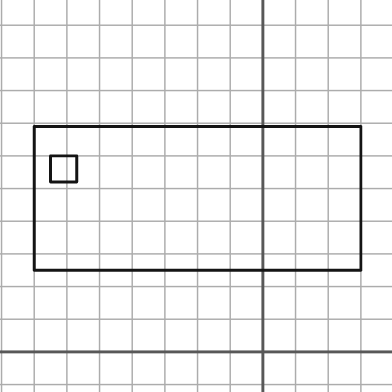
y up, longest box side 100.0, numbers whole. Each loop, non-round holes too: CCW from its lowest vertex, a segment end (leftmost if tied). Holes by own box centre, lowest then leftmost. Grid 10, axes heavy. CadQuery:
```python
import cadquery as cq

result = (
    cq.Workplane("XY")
    .moveTo(-70.0, 25.0)
    .lineTo(30.0, 25.0)
    .lineTo(30.0, 69.0)
    .lineTo(-70.0, 69.0)
    .close()
    .moveTo(-65.0, 52.0)
    .lineTo(-57.0, 52.0)
    .lineTo(-57.0, 60.0)
    .lineTo(-65.0, 60.0)
    .close()
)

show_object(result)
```